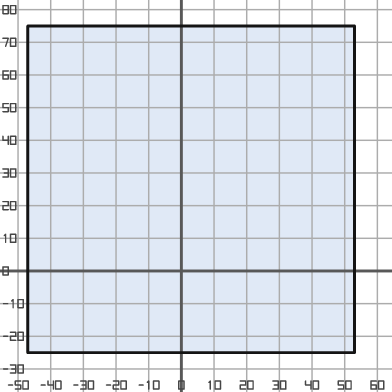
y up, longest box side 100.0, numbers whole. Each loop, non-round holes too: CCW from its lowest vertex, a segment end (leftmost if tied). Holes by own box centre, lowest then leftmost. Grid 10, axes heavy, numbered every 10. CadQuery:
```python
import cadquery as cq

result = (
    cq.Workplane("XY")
    .moveTo(-47.0, -25.0)
    .lineTo(53.0, -25.0)
    .lineTo(53.0, 75.0)
    .lineTo(-47.0, 75.0)
    .close()
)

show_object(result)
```